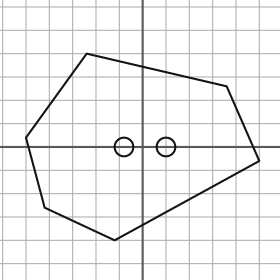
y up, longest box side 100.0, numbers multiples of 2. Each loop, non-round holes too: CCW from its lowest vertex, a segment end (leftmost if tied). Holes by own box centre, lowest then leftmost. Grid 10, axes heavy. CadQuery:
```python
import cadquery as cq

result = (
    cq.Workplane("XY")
    .moveTo(-12.0, -40.0)
    .lineTo(50.0, -6.0)
    .lineTo(36.0, 26.0)
    .lineTo(-24.0, 40.0)
    .lineTo(-50.0, 4.0)
    .lineTo(-42.0, -26.0)
    .close()
    .moveTo(-8.0, 0.0)
    .circle(4.0)
    .moveTo(10.0, 0.0)
    .circle(4.0)
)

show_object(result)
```